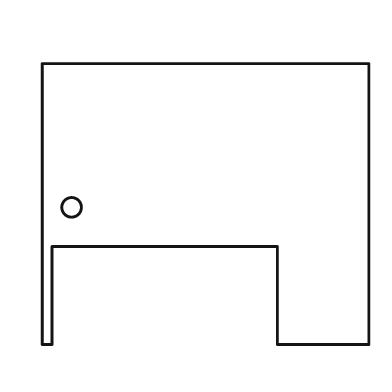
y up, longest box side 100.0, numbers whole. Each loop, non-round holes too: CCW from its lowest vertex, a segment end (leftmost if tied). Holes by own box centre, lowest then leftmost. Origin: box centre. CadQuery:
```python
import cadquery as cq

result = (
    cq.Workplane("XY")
    .moveTo(-50.0, -43.0)
    .lineTo(-47.0, -43.0)
    .lineTo(-47.0, -13.0)
    .lineTo(22.0, -13.0)
    .lineTo(22.0, -43.0)
    .lineTo(50.0, -43.0)
    .lineTo(50.0, 43.0)
    .lineTo(-50.0, 43.0)
    .close()
    .moveTo(-41.0, -1.0)
    .circle(3.0)
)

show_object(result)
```